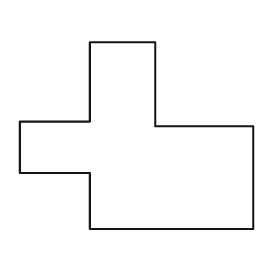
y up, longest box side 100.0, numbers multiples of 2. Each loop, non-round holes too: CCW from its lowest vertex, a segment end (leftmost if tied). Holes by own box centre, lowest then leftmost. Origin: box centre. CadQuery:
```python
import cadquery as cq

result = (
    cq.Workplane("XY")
    .moveTo(-20.0, -40.0)
    .lineTo(50.0, -40.0)
    .lineTo(50.0, 4.0)
    .lineTo(8.0, 4.0)
    .lineTo(8.0, 40.0)
    .lineTo(-20.0, 40.0)
    .lineTo(-20.0, 6.0)
    .lineTo(-50.0, 6.0)
    .lineTo(-50.0, -16.0)
    .lineTo(-20.0, -16.0)
    .close()
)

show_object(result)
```